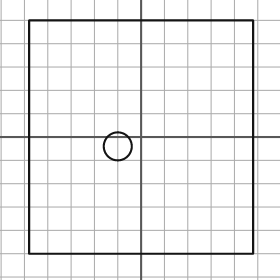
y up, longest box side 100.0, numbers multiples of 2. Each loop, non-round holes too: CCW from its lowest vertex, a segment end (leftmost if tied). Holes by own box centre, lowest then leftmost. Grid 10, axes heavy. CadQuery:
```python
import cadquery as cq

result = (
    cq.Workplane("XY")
    .moveTo(-48.0, -50.0)
    .lineTo(48.0, -50.0)
    .lineTo(48.0, 50.0)
    .lineTo(-48.0, 50.0)
    .close()
    .moveTo(-10.0, -4.0)
    .circle(6.0)
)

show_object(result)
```